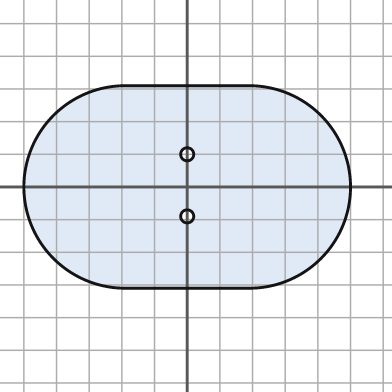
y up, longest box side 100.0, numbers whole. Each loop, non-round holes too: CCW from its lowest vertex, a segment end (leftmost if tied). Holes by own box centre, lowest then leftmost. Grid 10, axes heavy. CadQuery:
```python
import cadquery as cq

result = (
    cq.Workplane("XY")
    .moveTo(-19.0, -31.0)
    .lineTo(19.0, -31.0)
    .threePointArc((50.0, 0.0), (19.0, 31.0))
    .lineTo(-19.0, 31.0)
    .threePointArc((-50.0, 0.0), (-19.0, -31.0))
    .close()
    .moveTo(0.0, -9.0)
    .circle(2.0)
    .moveTo(0.0, 10.0)
    .circle(2.0)
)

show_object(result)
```